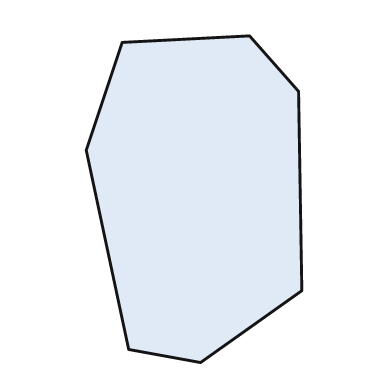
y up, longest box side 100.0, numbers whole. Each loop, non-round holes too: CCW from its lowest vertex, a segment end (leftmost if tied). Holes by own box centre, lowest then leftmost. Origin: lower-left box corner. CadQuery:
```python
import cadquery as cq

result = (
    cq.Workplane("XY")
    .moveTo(35.0, 0.0)
    .lineTo(66.0, 22.0)
    .lineTo(65.0, 83.0)
    .lineTo(50.0, 100.0)
    .lineTo(11.0, 98.0)
    .lineTo(0.0, 65.0)
    .lineTo(13.0, 4.0)
    .close()
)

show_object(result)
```